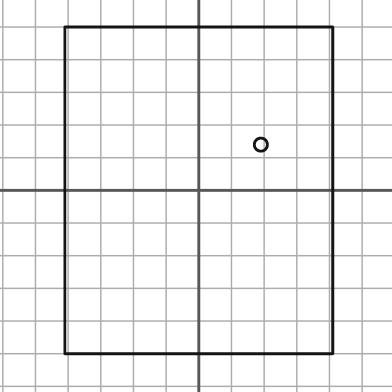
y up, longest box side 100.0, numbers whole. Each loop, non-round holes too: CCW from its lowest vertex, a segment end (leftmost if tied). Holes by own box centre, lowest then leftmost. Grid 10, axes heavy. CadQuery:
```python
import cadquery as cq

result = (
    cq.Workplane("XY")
    .moveTo(-41.0, -50.0)
    .lineTo(41.0, -50.0)
    .lineTo(41.0, 50.0)
    .lineTo(-41.0, 50.0)
    .close()
    .moveTo(19.0, 14.0)
    .circle(2.0)
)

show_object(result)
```